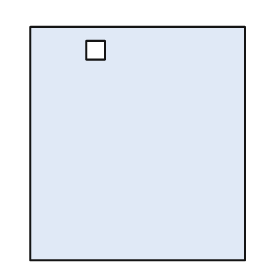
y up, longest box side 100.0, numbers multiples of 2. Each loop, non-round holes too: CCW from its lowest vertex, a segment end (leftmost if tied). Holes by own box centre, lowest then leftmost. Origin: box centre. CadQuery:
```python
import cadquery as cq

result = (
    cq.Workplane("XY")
    .moveTo(-46.0, -50.0)
    .lineTo(46.0, -50.0)
    .lineTo(46.0, 50.0)
    .lineTo(-46.0, 50.0)
    .close()
    .moveTo(-22.0, 36.0)
    .lineTo(-14.0, 36.0)
    .lineTo(-14.0, 44.0)
    .lineTo(-22.0, 44.0)
    .close()
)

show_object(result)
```